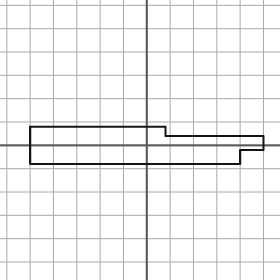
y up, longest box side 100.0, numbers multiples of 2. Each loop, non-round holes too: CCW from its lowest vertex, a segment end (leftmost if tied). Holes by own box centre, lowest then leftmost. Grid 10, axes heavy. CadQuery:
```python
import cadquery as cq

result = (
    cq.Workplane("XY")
    .moveTo(-50.0, -8.0)
    .lineTo(40.0, -8.0)
    .lineTo(40.0, -2.0)
    .lineTo(50.0, -2.0)
    .lineTo(50.0, 4.0)
    .lineTo(8.0, 4.0)
    .lineTo(8.0, 8.0)
    .lineTo(-50.0, 8.0)
    .close()
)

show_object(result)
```